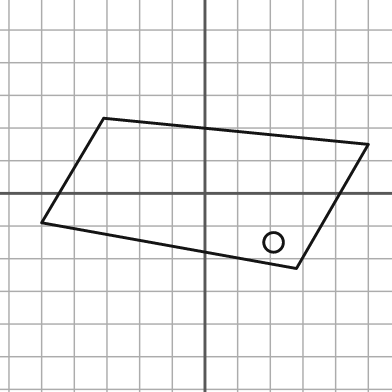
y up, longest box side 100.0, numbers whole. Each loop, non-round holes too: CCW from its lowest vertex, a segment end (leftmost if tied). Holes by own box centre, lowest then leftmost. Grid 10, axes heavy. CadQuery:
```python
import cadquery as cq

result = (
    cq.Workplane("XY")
    .moveTo(28.0, -23.0)
    .lineTo(50.0, 15.0)
    .lineTo(-31.0, 23.0)
    .lineTo(-50.0, -9.0)
    .close()
    .moveTo(21.0, -15.0)
    .circle(3.0)
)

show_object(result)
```